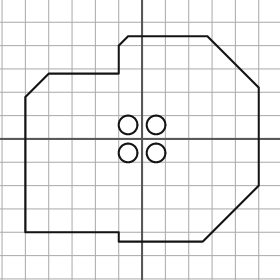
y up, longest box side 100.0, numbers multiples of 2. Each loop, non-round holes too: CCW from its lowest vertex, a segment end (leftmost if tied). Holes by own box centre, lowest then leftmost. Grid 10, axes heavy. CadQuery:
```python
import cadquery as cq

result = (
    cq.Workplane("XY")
    .moveTo(-10.0, -44.0)
    .lineTo(26.0, -44.0)
    .lineTo(50.0, -20.0)
    .lineTo(50.0, 22.0)
    .lineTo(28.0, 44.0)
    .lineTo(-6.0, 44.0)
    .lineTo(-10.0, 40.0)
    .lineTo(-10.0, 28.0)
    .lineTo(-40.0, 28.0)
    .lineTo(-50.0, 18.0)
    .lineTo(-50.0, -40.0)
    .lineTo(-10.0, -40.0)
    .close()
    .moveTo(-6.0, -6.0)
    .circle(4.0)
    .moveTo(6.0, -6.0)
    .circle(4.0)
    .moveTo(-6.0, 6.0)
    .circle(4.0)
    .moveTo(6.0, 6.0)
    .circle(4.0)
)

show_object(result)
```